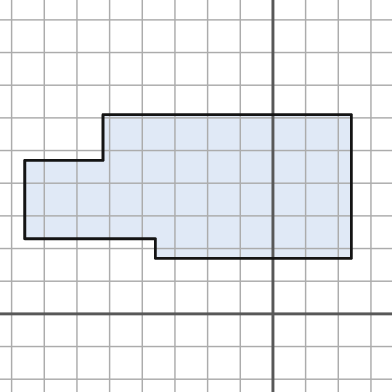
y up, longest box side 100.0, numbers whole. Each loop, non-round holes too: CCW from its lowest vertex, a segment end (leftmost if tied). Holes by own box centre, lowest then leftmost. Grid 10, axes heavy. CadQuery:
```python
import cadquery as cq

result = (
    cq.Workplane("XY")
    .moveTo(-36.0, 17.0)
    .lineTo(24.0, 17.0)
    .lineTo(24.0, 61.0)
    .lineTo(-52.0, 61.0)
    .lineTo(-52.0, 47.0)
    .lineTo(-76.0, 47.0)
    .lineTo(-76.0, 23.0)
    .lineTo(-36.0, 23.0)
    .close()
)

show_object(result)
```